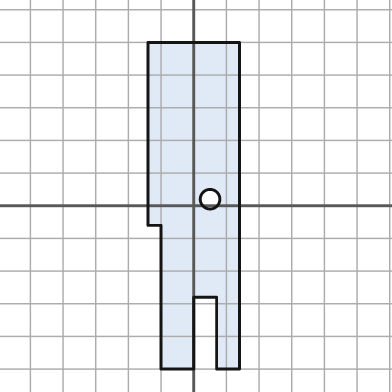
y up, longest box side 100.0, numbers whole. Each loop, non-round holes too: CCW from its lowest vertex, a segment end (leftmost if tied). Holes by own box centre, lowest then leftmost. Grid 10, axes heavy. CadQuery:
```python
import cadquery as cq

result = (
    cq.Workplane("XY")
    .moveTo(-10.0, -50.0)
    .lineTo(0.0, -50.0)
    .lineTo(0.0, -28.0)
    .lineTo(7.0, -28.0)
    .lineTo(7.0, -50.0)
    .lineTo(14.0, -50.0)
    .lineTo(14.0, 50.0)
    .lineTo(-14.0, 50.0)
    .lineTo(-14.0, -6.0)
    .lineTo(-10.0, -6.0)
    .close()
    .moveTo(5.0, 2.0)
    .circle(3.0)
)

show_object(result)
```